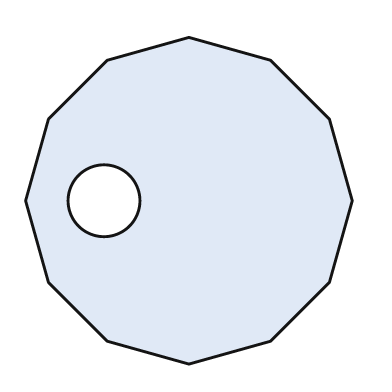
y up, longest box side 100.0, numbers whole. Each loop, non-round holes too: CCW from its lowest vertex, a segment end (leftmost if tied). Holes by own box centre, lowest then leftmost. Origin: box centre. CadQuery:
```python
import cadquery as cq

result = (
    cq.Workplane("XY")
    .moveTo(0.0, -50.0)
    .lineTo(25.0, -43.0)
    .lineTo(43.0, -25.0)
    .lineTo(50.0, 0.0)
    .lineTo(43.0, 25.0)
    .lineTo(25.0, 43.0)
    .lineTo(0.0, 50.0)
    .lineTo(-25.0, 43.0)
    .lineTo(-43.0, 25.0)
    .lineTo(-50.0, 0.0)
    .lineTo(-43.0, -25.0)
    .lineTo(-25.0, -43.0)
    .close()
    .moveTo(-26.0, 0.0)
    .circle(11.0)
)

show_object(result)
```